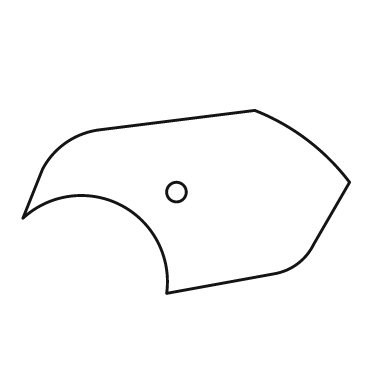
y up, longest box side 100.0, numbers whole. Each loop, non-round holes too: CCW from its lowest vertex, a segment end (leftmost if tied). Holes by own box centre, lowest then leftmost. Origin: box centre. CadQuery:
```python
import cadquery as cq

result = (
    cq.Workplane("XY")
    .moveTo(-6.0, -28.0)
    .lineTo(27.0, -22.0)
    .threePointArc((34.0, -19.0), (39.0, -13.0))
    .lineTo(50.0, 6.0)
    .threePointArc((37.0, 19.0), (21.0, 28.0))
    .lineTo(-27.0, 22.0)
    .threePointArc((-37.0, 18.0), (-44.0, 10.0))
    .lineTo(-50.0, -5.0)
    .threePointArc((-20.0, -1.0), (-6.0, -28.0))
    .close()
    .moveTo(-3.0, 3.0)
    .circle(3.0)
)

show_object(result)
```